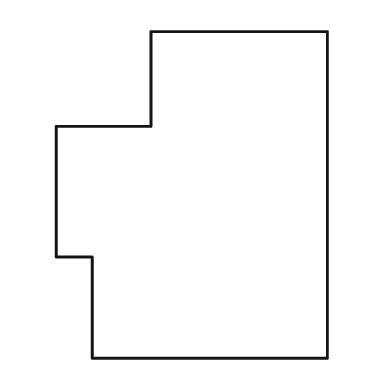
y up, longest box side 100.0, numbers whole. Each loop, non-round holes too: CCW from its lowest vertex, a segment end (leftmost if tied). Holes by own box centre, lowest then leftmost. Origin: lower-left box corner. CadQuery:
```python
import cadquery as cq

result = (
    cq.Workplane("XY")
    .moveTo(11.0, 0.0)
    .lineTo(83.0, 0.0)
    .lineTo(83.0, 100.0)
    .lineTo(29.0, 100.0)
    .lineTo(29.0, 71.0)
    .lineTo(0.0, 71.0)
    .lineTo(0.0, 31.0)
    .lineTo(11.0, 31.0)
    .close()
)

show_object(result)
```